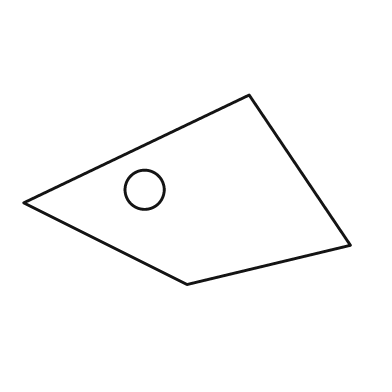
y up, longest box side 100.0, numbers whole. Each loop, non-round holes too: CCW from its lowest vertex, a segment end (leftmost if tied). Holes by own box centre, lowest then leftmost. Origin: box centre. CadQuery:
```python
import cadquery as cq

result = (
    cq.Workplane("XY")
    .moveTo(0.0, -29.0)
    .lineTo(50.0, -17.0)
    .lineTo(19.0, 29.0)
    .lineTo(-50.0, -4.0)
    .close()
    .moveTo(-13.0, 0.0)
    .circle(6.0)
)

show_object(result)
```